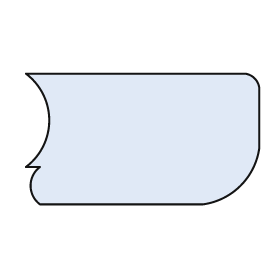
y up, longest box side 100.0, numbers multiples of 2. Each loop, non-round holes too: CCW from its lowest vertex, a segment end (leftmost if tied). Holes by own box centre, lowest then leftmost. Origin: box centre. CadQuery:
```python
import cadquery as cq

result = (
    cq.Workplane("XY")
    .moveTo(-44.0, -28.0)
    .lineTo(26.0, -28.0)
    .threePointArc((42.0, -20.0), (50.0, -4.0))
    .lineTo(50.0, 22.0)
    .threePointArc((48.0, 26.0), (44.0, 28.0))
    .lineTo(-50.0, 28.0)
    .threePointArc((-40.0, 8.0), (-50.0, -12.0))
    .lineTo(-44.0, -12.0)
    .threePointArc((-48.0, -20.0), (-44.0, -28.0))
    .close()
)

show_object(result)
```